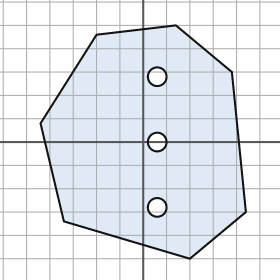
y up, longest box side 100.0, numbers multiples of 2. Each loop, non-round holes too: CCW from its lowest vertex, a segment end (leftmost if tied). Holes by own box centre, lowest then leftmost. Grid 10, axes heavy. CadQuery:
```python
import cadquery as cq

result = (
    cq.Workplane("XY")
    .moveTo(20.0, -50.0)
    .lineTo(44.0, -30.0)
    .lineTo(38.0, 30.0)
    .lineTo(14.0, 50.0)
    .lineTo(-20.0, 46.0)
    .lineTo(-44.0, 8.0)
    .lineTo(-34.0, -34.0)
    .close()
    .moveTo(6.0, -28.0)
    .circle(4.0)
    .moveTo(6.0, 0.0)
    .circle(4.0)
    .moveTo(6.0, 28.0)
    .circle(4.0)
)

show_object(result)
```